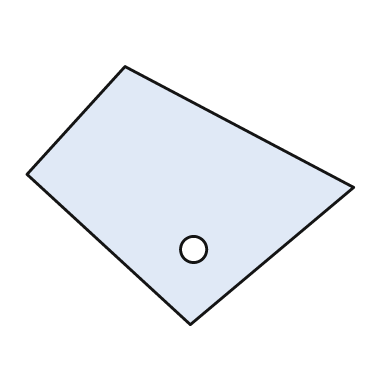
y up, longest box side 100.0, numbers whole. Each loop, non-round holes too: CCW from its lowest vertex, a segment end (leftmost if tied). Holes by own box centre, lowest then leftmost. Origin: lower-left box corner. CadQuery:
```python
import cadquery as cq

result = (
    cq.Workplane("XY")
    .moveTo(50.0, 0.0)
    .lineTo(100.0, 42.0)
    .lineTo(30.0, 79.0)
    .lineTo(0.0, 46.0)
    .close()
    .moveTo(51.0, 23.0)
    .circle(4.0)
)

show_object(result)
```